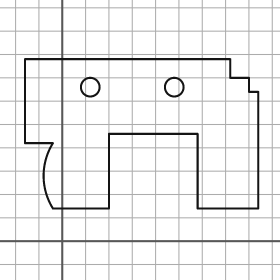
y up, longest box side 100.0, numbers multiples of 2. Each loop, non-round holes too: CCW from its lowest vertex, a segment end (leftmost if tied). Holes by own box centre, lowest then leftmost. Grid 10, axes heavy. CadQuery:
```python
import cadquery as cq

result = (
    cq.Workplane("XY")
    .moveTo(-4.0, 14.0)
    .lineTo(20.0, 14.0)
    .lineTo(20.0, 46.0)
    .lineTo(58.0, 46.0)
    .lineTo(58.0, 14.0)
    .lineTo(84.0, 14.0)
    .lineTo(84.0, 64.0)
    .lineTo(80.0, 64.0)
    .lineTo(80.0, 70.0)
    .lineTo(72.0, 70.0)
    .lineTo(72.0, 78.0)
    .lineTo(-16.0, 78.0)
    .lineTo(-16.0, 42.0)
    .lineTo(-4.0, 42.0)
    .threePointArc((-8.0, 28.0), (-4.0, 14.0))
    .close()
    .moveTo(12.0, 66.0)
    .circle(4.0)
    .moveTo(48.0, 66.0)
    .circle(4.0)
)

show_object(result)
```